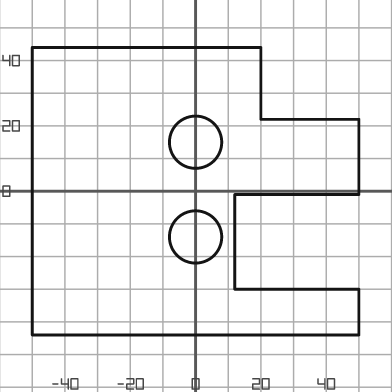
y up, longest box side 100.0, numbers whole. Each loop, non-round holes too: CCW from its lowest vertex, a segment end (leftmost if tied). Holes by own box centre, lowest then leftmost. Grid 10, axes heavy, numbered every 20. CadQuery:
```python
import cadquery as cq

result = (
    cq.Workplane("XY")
    .moveTo(-50.0, -44.0)
    .lineTo(50.0, -44.0)
    .lineTo(50.0, -30.0)
    .lineTo(12.0, -30.0)
    .lineTo(12.0, -1.0)
    .lineTo(50.0, -1.0)
    .lineTo(50.0, 22.0)
    .lineTo(20.0, 22.0)
    .lineTo(20.0, 44.0)
    .lineTo(-50.0, 44.0)
    .close()
    .moveTo(0.0, -14.0)
    .circle(8.0)
    .moveTo(0.0, 15.0)
    .circle(8.0)
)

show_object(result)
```